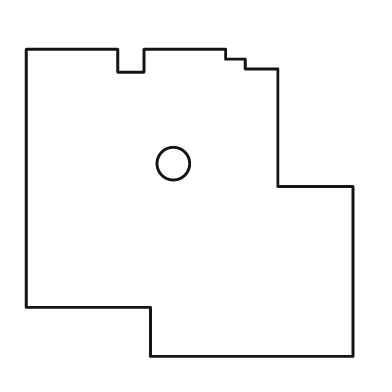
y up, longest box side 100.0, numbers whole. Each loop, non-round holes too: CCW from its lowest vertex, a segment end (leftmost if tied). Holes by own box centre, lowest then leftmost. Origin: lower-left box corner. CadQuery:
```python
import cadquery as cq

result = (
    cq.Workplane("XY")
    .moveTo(38.0, 0.0)
    .lineTo(100.0, 0.0)
    .lineTo(100.0, 52.0)
    .lineTo(77.0, 52.0)
    .lineTo(77.0, 88.0)
    .lineTo(67.0, 88.0)
    .lineTo(67.0, 91.0)
    .lineTo(61.0, 91.0)
    .lineTo(61.0, 94.0)
    .lineTo(36.0, 94.0)
    .lineTo(36.0, 87.0)
    .lineTo(28.0, 87.0)
    .lineTo(28.0, 94.0)
    .lineTo(0.0, 94.0)
    .lineTo(0.0, 15.0)
    .lineTo(38.0, 15.0)
    .close()
    .moveTo(45.0, 59.0)
    .circle(5.0)
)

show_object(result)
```